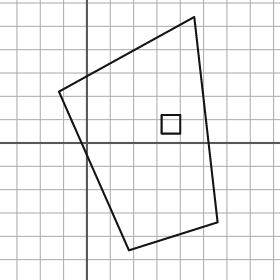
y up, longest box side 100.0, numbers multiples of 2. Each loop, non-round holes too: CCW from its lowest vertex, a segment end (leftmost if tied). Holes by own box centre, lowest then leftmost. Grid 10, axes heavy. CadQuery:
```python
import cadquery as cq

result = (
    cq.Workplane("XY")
    .moveTo(18.0, -46.0)
    .lineTo(56.0, -34.0)
    .lineTo(46.0, 54.0)
    .lineTo(-12.0, 22.0)
    .close()
    .moveTo(32.0, 4.0)
    .lineTo(40.0, 4.0)
    .lineTo(40.0, 12.0)
    .lineTo(32.0, 12.0)
    .close()
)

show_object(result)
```